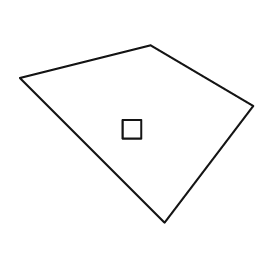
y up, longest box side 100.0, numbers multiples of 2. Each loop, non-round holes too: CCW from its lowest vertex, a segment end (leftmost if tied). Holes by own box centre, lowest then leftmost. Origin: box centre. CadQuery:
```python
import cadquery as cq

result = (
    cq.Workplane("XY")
    .moveTo(12.0, -38.0)
    .lineTo(50.0, 12.0)
    .lineTo(6.0, 38.0)
    .lineTo(-50.0, 24.0)
    .close()
    .moveTo(-6.0, -2.0)
    .lineTo(2.0, -2.0)
    .lineTo(2.0, 6.0)
    .lineTo(-6.0, 6.0)
    .close()
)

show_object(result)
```